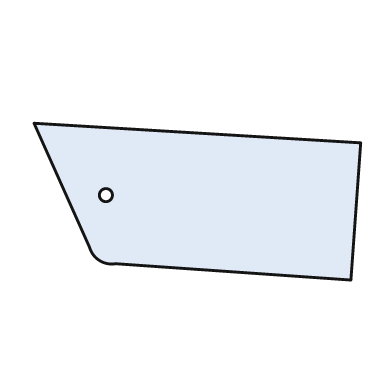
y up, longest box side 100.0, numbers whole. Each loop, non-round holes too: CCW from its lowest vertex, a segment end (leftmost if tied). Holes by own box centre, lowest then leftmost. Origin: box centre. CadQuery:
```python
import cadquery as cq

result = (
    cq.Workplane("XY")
    .moveTo(47.0, -24.0)
    .lineTo(50.0, 18.0)
    .lineTo(-50.0, 24.0)
    .lineTo(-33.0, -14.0)
    .threePointArc((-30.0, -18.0), (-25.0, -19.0))
    .close()
    .moveTo(-28.0, 2.0)
    .circle(2.0)
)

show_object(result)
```